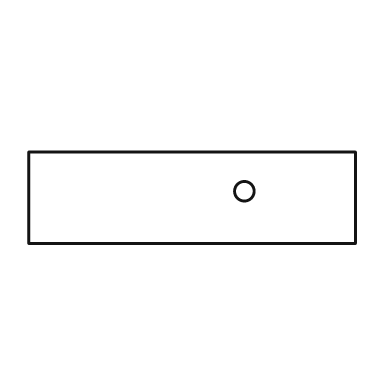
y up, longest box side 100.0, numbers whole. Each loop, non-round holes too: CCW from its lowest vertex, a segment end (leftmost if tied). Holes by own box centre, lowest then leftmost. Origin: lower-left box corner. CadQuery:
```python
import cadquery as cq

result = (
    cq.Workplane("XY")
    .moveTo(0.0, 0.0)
    .lineTo(100.0, 0.0)
    .lineTo(100.0, 28.0)
    .lineTo(0.0, 28.0)
    .close()
    .moveTo(66.0, 16.0)
    .circle(3.0)
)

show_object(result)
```